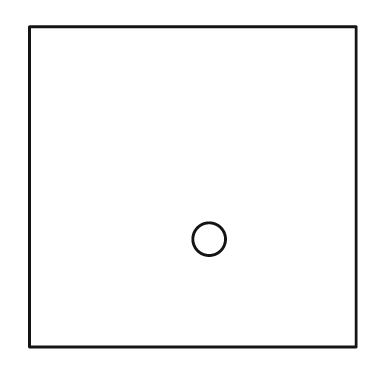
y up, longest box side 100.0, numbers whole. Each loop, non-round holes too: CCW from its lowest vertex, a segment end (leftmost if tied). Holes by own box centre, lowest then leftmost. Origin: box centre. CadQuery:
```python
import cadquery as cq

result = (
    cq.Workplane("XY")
    .moveTo(-50.0, -49.0)
    .lineTo(50.0, -49.0)
    .lineTo(50.0, 49.0)
    .lineTo(-50.0, 49.0)
    .close()
    .moveTo(5.0, -16.0)
    .circle(5.0)
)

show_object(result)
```